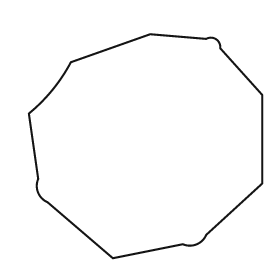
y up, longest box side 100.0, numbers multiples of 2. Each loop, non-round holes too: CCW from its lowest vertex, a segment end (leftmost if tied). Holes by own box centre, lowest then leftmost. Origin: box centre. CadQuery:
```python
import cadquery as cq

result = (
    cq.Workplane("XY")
    .moveTo(-14.0, -48.0)
    .lineTo(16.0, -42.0)
    .threePointArc((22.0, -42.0), (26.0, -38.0))
    .lineTo(50.0, -16.0)
    .lineTo(50.0, 22.0)
    .lineTo(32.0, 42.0)
    .threePointArc((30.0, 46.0), (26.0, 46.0))
    .lineTo(2.0, 48.0)
    .lineTo(-32.0, 36.0)
    .threePointArc((-40.0, 24.0), (-50.0, 14.0))
    .lineTo(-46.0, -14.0)
    .threePointArc((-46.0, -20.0), (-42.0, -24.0))
    .close()
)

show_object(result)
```